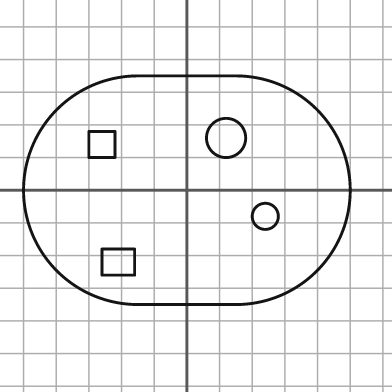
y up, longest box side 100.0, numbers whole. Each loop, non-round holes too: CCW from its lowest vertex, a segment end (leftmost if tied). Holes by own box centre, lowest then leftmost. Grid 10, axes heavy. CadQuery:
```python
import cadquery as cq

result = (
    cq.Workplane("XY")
    .moveTo(-15.0, -35.0)
    .lineTo(15.0, -35.0)
    .threePointArc((50.0, 0.0), (15.0, 35.0))
    .lineTo(-15.0, 35.0)
    .threePointArc((-50.0, 0.0), (-15.0, -35.0))
    .close()
    .moveTo(-26.0, -26.0)
    .lineTo(-16.0, -26.0)
    .lineTo(-16.0, -18.0)
    .lineTo(-26.0, -18.0)
    .close()
    .moveTo(24.0, -8.0)
    .circle(4.0)
    .moveTo(-30.0, 10.0)
    .lineTo(-22.0, 10.0)
    .lineTo(-22.0, 18.0)
    .lineTo(-30.0, 18.0)
    .close()
    .moveTo(12.0, 16.0)
    .circle(6.0)
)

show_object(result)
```